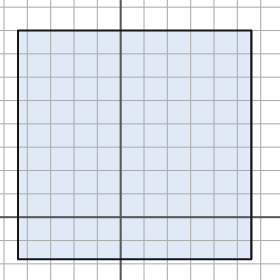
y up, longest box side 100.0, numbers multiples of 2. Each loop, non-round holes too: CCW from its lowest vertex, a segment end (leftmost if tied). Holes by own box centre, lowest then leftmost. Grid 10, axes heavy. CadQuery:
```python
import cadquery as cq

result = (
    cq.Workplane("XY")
    .moveTo(-44.0, -18.0)
    .lineTo(56.0, -18.0)
    .lineTo(56.0, 80.0)
    .lineTo(-44.0, 80.0)
    .close()
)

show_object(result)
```